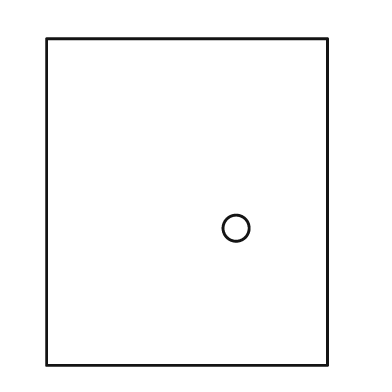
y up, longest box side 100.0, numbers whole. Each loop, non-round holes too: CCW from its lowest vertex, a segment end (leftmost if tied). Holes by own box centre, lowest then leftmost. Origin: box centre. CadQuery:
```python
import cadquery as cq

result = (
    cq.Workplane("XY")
    .moveTo(-43.0, -50.0)
    .lineTo(43.0, -50.0)
    .lineTo(43.0, 50.0)
    .lineTo(-43.0, 50.0)
    .close()
    .moveTo(15.0, -8.0)
    .circle(4.0)
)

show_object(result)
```